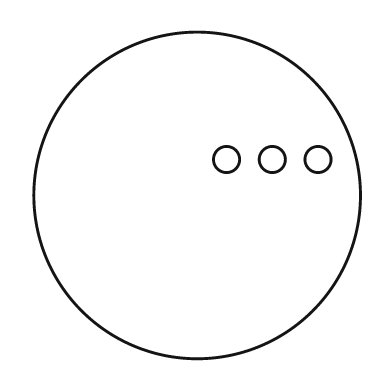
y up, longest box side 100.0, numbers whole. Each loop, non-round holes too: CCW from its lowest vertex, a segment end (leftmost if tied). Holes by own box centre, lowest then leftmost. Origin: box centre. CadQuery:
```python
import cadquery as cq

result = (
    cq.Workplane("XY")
    .moveTo(0.0, 0.0)
    .circle(50.0)
    .moveTo(9.0, 11.0)
    .circle(4.0)
    .moveTo(23.0, 11.0)
    .circle(4.0)
    .moveTo(37.0, 11.0)
    .circle(4.0)
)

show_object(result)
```